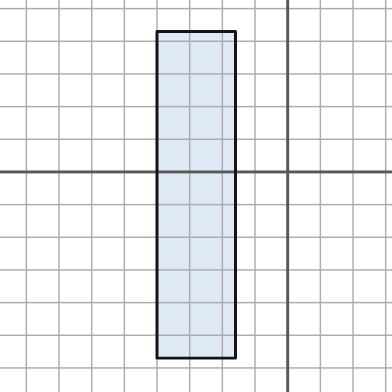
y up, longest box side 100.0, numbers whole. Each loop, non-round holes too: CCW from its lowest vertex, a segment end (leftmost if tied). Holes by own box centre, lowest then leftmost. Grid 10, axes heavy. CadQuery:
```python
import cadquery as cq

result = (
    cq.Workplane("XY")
    .moveTo(-40.0, -57.0)
    .lineTo(-16.0, -57.0)
    .lineTo(-16.0, 43.0)
    .lineTo(-40.0, 43.0)
    .close()
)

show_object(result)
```